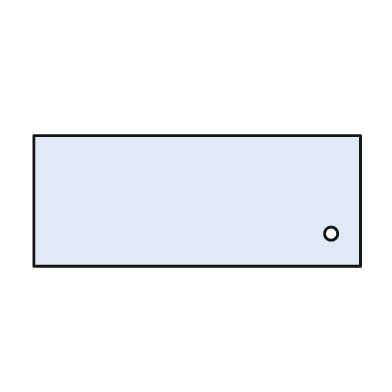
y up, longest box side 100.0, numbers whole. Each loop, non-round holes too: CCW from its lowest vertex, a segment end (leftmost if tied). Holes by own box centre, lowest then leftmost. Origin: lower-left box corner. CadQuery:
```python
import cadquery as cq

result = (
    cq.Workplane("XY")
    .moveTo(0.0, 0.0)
    .lineTo(100.0, 0.0)
    .lineTo(100.0, 40.0)
    .lineTo(0.0, 40.0)
    .close()
    .moveTo(91.0, 10.0)
    .circle(2.0)
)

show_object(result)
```